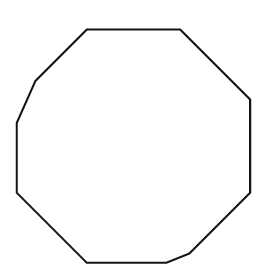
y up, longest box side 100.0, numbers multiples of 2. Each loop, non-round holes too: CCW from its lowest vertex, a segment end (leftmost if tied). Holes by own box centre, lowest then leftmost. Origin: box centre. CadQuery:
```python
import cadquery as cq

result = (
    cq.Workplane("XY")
    .moveTo(-20.0, -50.0)
    .lineTo(14.0, -50.0)
    .lineTo(24.0, -46.0)
    .lineTo(50.0, -20.0)
    .lineTo(50.0, 20.0)
    .lineTo(20.0, 50.0)
    .lineTo(-20.0, 50.0)
    .lineTo(-42.0, 28.0)
    .lineTo(-50.0, 10.0)
    .lineTo(-50.0, -20.0)
    .close()
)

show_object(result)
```